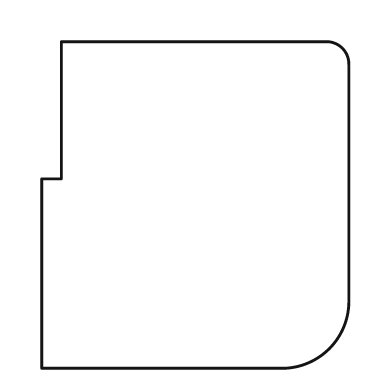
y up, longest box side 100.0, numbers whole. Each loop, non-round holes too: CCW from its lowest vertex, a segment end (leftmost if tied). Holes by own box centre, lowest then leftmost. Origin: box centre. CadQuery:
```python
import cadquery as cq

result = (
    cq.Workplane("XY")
    .moveTo(-47.0, -50.0)
    .lineTo(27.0, -50.0)
    .threePointArc((41.0, -44.0), (47.0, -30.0))
    .lineTo(47.0, 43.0)
    .threePointArc((45.0, 48.0), (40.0, 50.0))
    .lineTo(-41.0, 50.0)
    .lineTo(-41.0, 8.0)
    .lineTo(-47.0, 8.0)
    .close()
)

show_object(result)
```